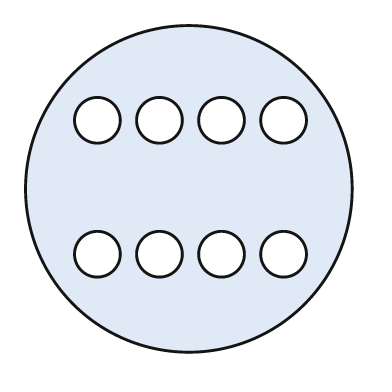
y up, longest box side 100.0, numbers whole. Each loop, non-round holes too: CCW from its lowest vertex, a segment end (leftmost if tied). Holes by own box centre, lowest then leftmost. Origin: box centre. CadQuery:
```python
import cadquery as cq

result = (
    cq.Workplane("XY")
    .moveTo(0.0, 0.0)
    .circle(50.0)
    .moveTo(-28.0, -20.0)
    .circle(7.0)
    .moveTo(-9.0, -20.0)
    .circle(7.0)
    .moveTo(10.0, -20.0)
    .circle(7.0)
    .moveTo(29.0, -20.0)
    .circle(7.0)
    .moveTo(-28.0, 21.0)
    .circle(7.0)
    .moveTo(-9.0, 21.0)
    .circle(7.0)
    .moveTo(10.0, 21.0)
    .circle(7.0)
    .moveTo(29.0, 21.0)
    .circle(7.0)
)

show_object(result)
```